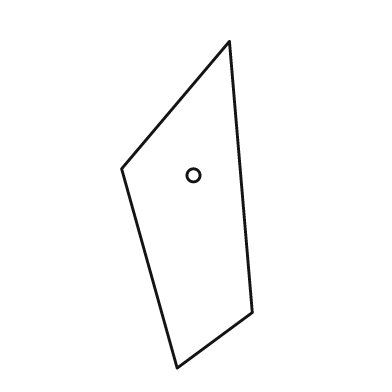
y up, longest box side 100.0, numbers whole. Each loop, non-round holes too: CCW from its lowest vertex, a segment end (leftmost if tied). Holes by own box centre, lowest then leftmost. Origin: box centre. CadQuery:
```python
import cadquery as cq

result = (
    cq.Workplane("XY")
    .moveTo(-3.0, -50.0)
    .lineTo(20.0, -33.0)
    .lineTo(13.0, 50.0)
    .lineTo(-20.0, 11.0)
    .close()
    .moveTo(2.0, 9.0)
    .circle(2.0)
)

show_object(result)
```